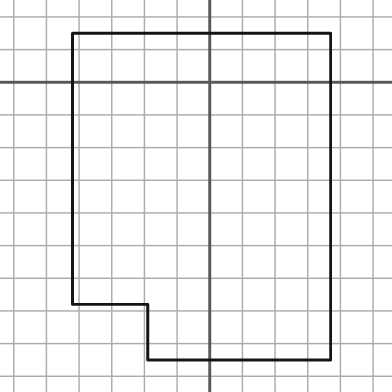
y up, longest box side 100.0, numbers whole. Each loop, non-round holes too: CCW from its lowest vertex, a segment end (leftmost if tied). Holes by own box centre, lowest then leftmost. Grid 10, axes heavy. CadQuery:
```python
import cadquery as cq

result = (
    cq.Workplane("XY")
    .moveTo(-19.0, -85.0)
    .lineTo(37.0, -85.0)
    .lineTo(37.0, 15.0)
    .lineTo(-42.0, 15.0)
    .lineTo(-42.0, -68.0)
    .lineTo(-19.0, -68.0)
    .close()
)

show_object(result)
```